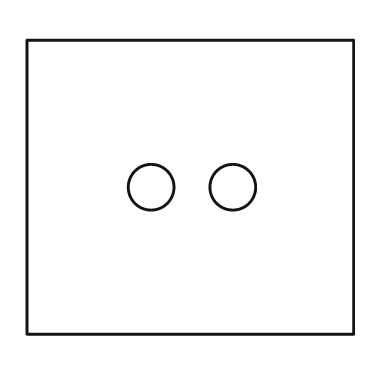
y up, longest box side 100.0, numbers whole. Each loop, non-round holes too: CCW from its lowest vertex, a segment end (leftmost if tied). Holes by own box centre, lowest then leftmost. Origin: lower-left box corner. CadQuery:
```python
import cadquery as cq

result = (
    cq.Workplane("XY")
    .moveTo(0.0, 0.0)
    .lineTo(100.0, 0.0)
    .lineTo(100.0, 90.0)
    .lineTo(0.0, 90.0)
    .close()
    .moveTo(38.0, 45.0)
    .circle(7.0)
    .moveTo(63.0, 45.0)
    .circle(7.0)
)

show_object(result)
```